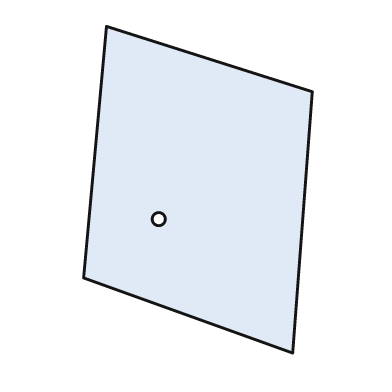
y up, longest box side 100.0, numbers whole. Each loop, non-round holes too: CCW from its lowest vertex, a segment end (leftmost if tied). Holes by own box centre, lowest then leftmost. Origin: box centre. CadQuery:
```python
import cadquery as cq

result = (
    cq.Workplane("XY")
    .moveTo(29.0, -50.0)
    .lineTo(35.0, 30.0)
    .lineTo(-28.0, 50.0)
    .lineTo(-35.0, -27.0)
    .close()
    .moveTo(-12.0, -9.0)
    .circle(2.0)
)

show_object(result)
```